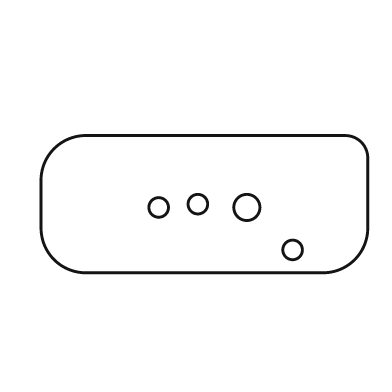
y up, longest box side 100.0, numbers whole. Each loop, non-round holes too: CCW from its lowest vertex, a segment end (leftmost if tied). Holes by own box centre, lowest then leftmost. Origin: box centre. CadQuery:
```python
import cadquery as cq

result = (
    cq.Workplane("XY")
    .moveTo(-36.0, -21.0)
    .lineTo(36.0, -21.0)
    .threePointArc((46.0, -17.0), (50.0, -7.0))
    .lineTo(50.0, 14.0)
    .threePointArc((48.0, 19.0), (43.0, 21.0))
    .lineTo(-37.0, 21.0)
    .threePointArc((-46.0, 17.0), (-50.0, 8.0))
    .lineTo(-50.0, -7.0)
    .threePointArc((-46.0, -17.0), (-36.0, -21.0))
    .close()
    .moveTo(27.0, -14.0)
    .circle(3.0)
    .moveTo(-14.0, -1.0)
    .circle(3.0)
    .moveTo(13.0, -1.0)
    .circle(4.0)
    .moveTo(-2.0, 0.0)
    .circle(3.0)
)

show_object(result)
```